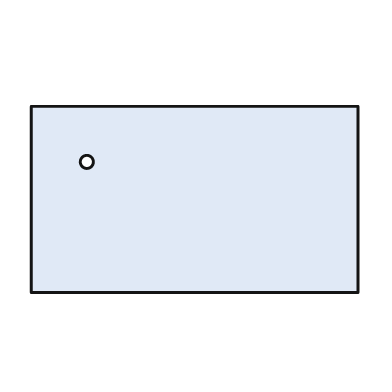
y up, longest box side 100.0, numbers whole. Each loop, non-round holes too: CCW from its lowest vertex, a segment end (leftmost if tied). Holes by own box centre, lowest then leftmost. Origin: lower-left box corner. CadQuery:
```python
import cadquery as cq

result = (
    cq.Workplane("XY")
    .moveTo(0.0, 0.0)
    .lineTo(100.0, 0.0)
    .lineTo(100.0, 57.0)
    .lineTo(0.0, 57.0)
    .close()
    .moveTo(17.0, 40.0)
    .circle(2.0)
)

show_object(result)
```